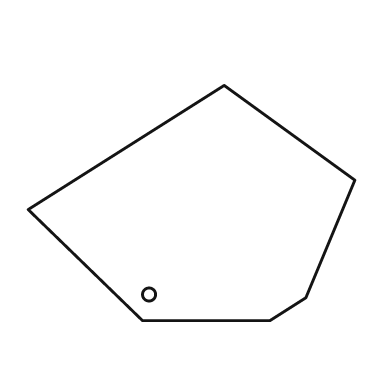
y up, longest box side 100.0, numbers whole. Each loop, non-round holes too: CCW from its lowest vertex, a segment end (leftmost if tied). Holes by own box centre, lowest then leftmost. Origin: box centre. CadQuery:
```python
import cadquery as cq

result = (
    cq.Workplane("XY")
    .moveTo(-15.0, -36.0)
    .lineTo(24.0, -36.0)
    .lineTo(35.0, -29.0)
    .lineTo(50.0, 7.0)
    .lineTo(10.0, 36.0)
    .lineTo(-50.0, -2.0)
    .close()
    .moveTo(-13.0, -28.0)
    .circle(2.0)
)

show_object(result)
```